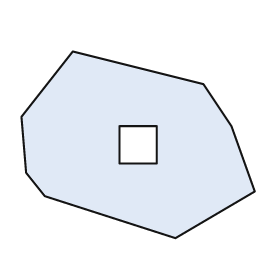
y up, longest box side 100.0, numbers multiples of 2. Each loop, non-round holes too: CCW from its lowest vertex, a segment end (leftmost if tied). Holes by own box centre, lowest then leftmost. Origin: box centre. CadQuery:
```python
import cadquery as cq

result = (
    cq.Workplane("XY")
    .moveTo(16.0, -40.0)
    .lineTo(50.0, -20.0)
    .lineTo(40.0, 8.0)
    .lineTo(28.0, 26.0)
    .lineTo(-28.0, 40.0)
    .lineTo(-50.0, 12.0)
    .lineTo(-48.0, -12.0)
    .lineTo(-40.0, -22.0)
    .close()
    .moveTo(-8.0, -8.0)
    .lineTo(8.0, -8.0)
    .lineTo(8.0, 8.0)
    .lineTo(-8.0, 8.0)
    .close()
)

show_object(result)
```